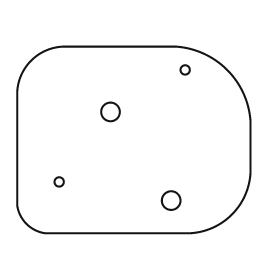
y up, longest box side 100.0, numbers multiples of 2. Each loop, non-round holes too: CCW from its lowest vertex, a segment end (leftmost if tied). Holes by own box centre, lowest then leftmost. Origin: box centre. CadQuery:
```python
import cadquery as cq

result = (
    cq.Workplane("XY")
    .moveTo(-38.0, -40.0)
    .lineTo(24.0, -40.0)
    .threePointArc((42.0, -32.0), (50.0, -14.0))
    .lineTo(50.0, 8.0)
    .threePointArc((40.0, 30.0), (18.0, 40.0))
    .lineTo(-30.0, 40.0)
    .threePointArc((-44.0, 34.0), (-50.0, 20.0))
    .lineTo(-50.0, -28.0)
    .threePointArc((-46.0, -36.0), (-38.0, -40.0))
    .close()
    .moveTo(16.0, -26.0)
    .circle(4.0)
    .moveTo(-32.0, -18.0)
    .circle(2.0)
    .moveTo(-10.0, 12.0)
    .circle(4.0)
    .moveTo(22.0, 30.0)
    .circle(2.0)
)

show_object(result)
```